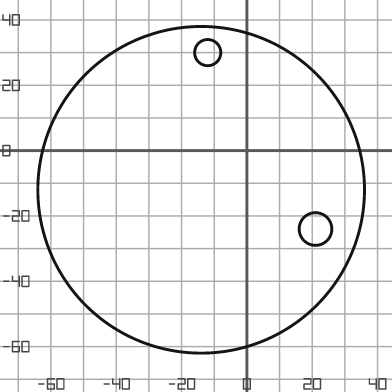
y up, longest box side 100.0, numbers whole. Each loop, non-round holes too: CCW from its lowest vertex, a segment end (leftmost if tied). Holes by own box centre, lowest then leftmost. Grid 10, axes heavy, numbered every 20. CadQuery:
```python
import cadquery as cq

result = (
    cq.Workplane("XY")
    .moveTo(-14.0, -12.0)
    .circle(50.0)
    .moveTo(21.0, -24.0)
    .circle(5.0)
    .moveTo(-12.0, 30.0)
    .circle(4.0)
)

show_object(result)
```